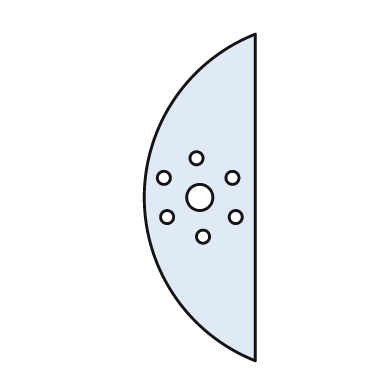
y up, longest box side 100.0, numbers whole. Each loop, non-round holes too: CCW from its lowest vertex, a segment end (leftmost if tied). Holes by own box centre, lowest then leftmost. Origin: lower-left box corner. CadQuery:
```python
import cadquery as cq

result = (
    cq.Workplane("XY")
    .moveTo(34.0, 0.0)
    .lineTo(34.0, 100.0)
    .threePointArc((0.0, 50.0), (34.0, 0.0))
    .close()
    .moveTo(18.0, 38.0)
    .circle(2.0)
    .moveTo(7.0, 44.0)
    .circle(2.0)
    .moveTo(28.0, 44.0)
    .circle(2.0)
    .moveTo(17.0, 50.0)
    .circle(4.0)
    .moveTo(6.0, 56.0)
    .circle(2.0)
    .moveTo(27.0, 56.0)
    .circle(2.0)
    .moveTo(16.0, 62.0)
    .circle(2.0)
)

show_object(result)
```